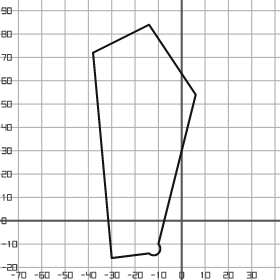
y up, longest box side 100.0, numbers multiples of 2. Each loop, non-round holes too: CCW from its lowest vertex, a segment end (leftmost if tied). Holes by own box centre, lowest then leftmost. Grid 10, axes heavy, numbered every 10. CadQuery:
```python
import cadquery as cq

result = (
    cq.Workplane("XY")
    .moveTo(-30.0, -16.0)
    .lineTo(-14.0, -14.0)
    .threePointArc((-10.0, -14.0), (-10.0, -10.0))
    .lineTo(6.0, 54.0)
    .lineTo(-14.0, 84.0)
    .lineTo(-38.0, 72.0)
    .close()
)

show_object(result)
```